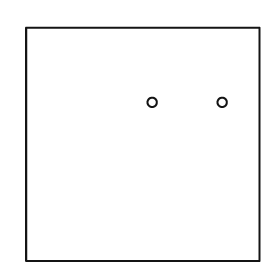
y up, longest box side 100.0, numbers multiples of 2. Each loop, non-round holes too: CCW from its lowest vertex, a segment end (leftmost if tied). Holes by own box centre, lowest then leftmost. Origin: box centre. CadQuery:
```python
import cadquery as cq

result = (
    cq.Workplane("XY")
    .moveTo(-50.0, -50.0)
    .lineTo(50.0, -50.0)
    .lineTo(50.0, 50.0)
    .lineTo(-50.0, 50.0)
    .close()
    .moveTo(4.0, 18.0)
    .circle(2.0)
    .moveTo(34.0, 18.0)
    .circle(2.0)
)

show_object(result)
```